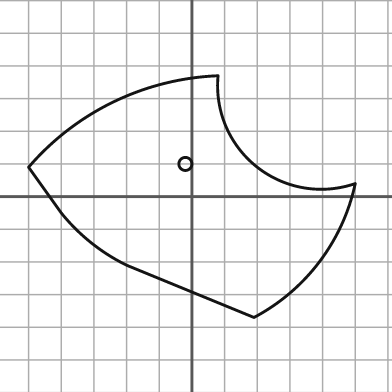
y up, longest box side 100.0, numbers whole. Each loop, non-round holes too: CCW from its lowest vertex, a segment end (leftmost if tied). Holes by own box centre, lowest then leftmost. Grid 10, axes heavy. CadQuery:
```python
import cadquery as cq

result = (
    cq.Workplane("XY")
    .moveTo(19.0, -37.0)
    .threePointArc((39.0, -20.0), (50.0, 4.0))
    .threePointArc((20.0, 9.0), (8.0, 37.0))
    .threePointArc((-24.0, 29.0), (-50.0, 9.0))
    .lineTo(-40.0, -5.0)
    .threePointArc((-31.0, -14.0), (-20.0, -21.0))
    .close()
    .moveTo(-2.0, 10.0)
    .circle(2.0)
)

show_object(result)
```